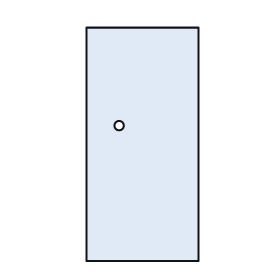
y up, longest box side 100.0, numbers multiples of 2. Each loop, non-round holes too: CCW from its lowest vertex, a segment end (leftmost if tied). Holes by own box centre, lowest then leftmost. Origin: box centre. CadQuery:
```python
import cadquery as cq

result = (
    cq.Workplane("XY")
    .moveTo(-24.0, -50.0)
    .lineTo(24.0, -50.0)
    .lineTo(24.0, 50.0)
    .lineTo(-24.0, 50.0)
    .close()
    .moveTo(-10.0, 8.0)
    .circle(2.0)
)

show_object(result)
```